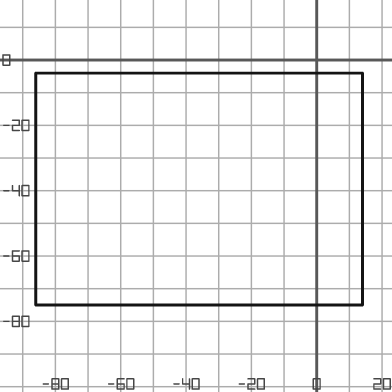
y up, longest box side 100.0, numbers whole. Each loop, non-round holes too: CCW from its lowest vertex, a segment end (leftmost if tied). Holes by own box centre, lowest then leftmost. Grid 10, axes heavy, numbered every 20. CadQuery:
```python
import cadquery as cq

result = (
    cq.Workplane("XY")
    .moveTo(-86.0, -75.0)
    .lineTo(14.0, -75.0)
    .lineTo(14.0, -4.0)
    .lineTo(-86.0, -4.0)
    .close()
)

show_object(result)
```